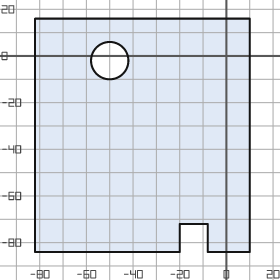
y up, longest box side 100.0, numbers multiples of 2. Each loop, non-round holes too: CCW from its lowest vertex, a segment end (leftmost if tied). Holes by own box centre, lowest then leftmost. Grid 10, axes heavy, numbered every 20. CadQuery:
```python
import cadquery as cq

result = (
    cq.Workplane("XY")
    .moveTo(-82.0, -84.0)
    .lineTo(-20.0, -84.0)
    .lineTo(-20.0, -72.0)
    .lineTo(-8.0, -72.0)
    .lineTo(-8.0, -84.0)
    .lineTo(10.0, -84.0)
    .lineTo(10.0, 16.0)
    .lineTo(-82.0, 16.0)
    .close()
    .moveTo(-50.0, -2.0)
    .circle(8.0)
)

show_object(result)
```